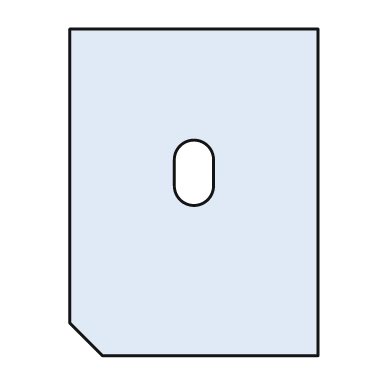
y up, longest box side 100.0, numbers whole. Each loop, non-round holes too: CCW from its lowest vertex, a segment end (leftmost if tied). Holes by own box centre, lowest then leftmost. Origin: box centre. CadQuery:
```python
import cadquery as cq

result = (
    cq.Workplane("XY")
    .moveTo(-28.0, -50.0)
    .lineTo(38.0, -50.0)
    .lineTo(38.0, 50.0)
    .lineTo(-38.0, 50.0)
    .lineTo(-38.0, -40.0)
    .close()
    .moveTo(-6.0, 2.0)
    .threePointArc((0.0, -4.0), (6.0, 2.0))
    .lineTo(6.0, 10.0)
    .threePointArc((0.0, 16.0), (-6.0, 10.0))
    .close()
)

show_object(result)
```